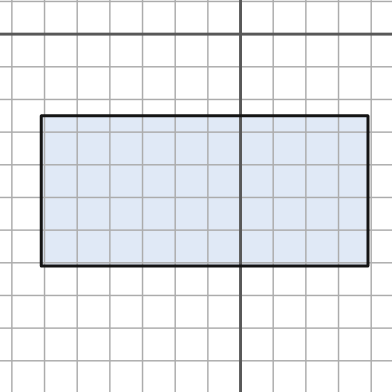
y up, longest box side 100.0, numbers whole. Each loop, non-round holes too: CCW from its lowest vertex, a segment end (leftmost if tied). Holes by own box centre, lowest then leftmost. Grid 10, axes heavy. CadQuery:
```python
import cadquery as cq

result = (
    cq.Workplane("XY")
    .moveTo(-61.0, -71.0)
    .lineTo(39.0, -71.0)
    .lineTo(39.0, -25.0)
    .lineTo(-61.0, -25.0)
    .close()
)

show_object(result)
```